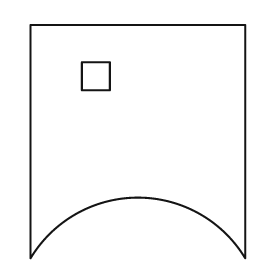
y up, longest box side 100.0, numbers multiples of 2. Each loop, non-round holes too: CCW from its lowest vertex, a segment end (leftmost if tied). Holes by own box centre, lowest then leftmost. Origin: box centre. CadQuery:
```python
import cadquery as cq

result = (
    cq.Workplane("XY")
    .moveTo(-46.0, -50.0)
    .threePointArc((0.0, -24.0), (46.0, -50.0))
    .lineTo(46.0, 50.0)
    .lineTo(-46.0, 50.0)
    .close()
    .moveTo(-24.0, 22.0)
    .lineTo(-12.0, 22.0)
    .lineTo(-12.0, 34.0)
    .lineTo(-24.0, 34.0)
    .close()
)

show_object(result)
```